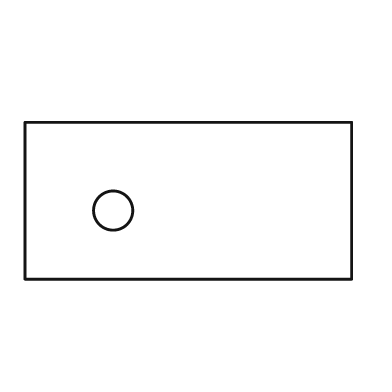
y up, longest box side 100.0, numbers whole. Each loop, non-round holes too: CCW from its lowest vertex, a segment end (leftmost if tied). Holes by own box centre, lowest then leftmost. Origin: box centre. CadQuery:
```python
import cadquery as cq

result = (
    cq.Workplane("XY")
    .moveTo(-50.0, -24.0)
    .lineTo(50.0, -24.0)
    .lineTo(50.0, 24.0)
    .lineTo(-50.0, 24.0)
    .close()
    .moveTo(-23.0, -3.0)
    .circle(6.0)
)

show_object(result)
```